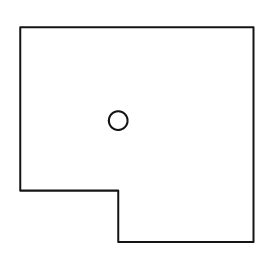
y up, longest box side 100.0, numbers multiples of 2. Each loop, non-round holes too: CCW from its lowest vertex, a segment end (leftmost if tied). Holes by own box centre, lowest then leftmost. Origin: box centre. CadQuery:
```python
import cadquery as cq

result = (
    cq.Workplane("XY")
    .moveTo(-8.0, -46.0)
    .lineTo(50.0, -46.0)
    .lineTo(50.0, 46.0)
    .lineTo(-50.0, 46.0)
    .lineTo(-50.0, -24.0)
    .lineTo(-8.0, -24.0)
    .close()
    .moveTo(-8.0, 6.0)
    .circle(4.0)
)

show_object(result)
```